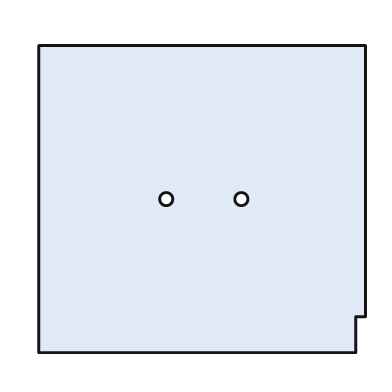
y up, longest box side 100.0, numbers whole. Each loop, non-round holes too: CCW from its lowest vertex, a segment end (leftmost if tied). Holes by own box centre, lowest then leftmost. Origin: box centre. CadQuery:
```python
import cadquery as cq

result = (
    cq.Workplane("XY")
    .moveTo(-50.0, -47.0)
    .lineTo(47.0, -47.0)
    .lineTo(47.0, -36.0)
    .lineTo(50.0, -36.0)
    .lineTo(50.0, 47.0)
    .lineTo(-50.0, 47.0)
    .close()
    .moveTo(-11.0, 0.0)
    .circle(2.0)
    .moveTo(12.0, 0.0)
    .circle(2.0)
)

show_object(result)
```